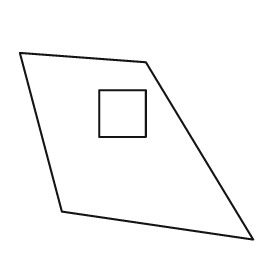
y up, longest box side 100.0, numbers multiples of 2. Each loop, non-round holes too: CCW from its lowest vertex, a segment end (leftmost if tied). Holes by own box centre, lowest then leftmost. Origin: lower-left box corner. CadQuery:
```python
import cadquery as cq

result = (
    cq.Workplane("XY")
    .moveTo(100.0, 0.0)
    .lineTo(54.0, 76.0)
    .lineTo(0.0, 80.0)
    .lineTo(18.0, 12.0)
    .close()
    .moveTo(34.0, 44.0)
    .lineTo(54.0, 44.0)
    .lineTo(54.0, 64.0)
    .lineTo(34.0, 64.0)
    .close()
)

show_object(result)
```